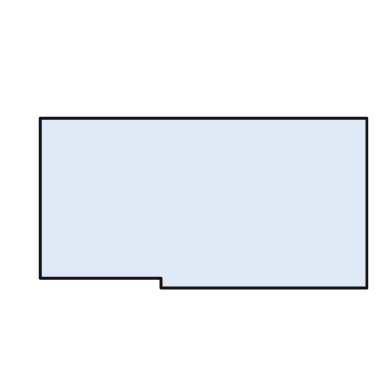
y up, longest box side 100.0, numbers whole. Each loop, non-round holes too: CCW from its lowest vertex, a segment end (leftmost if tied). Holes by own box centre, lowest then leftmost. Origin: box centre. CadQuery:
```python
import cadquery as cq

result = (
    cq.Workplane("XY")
    .moveTo(-13.0, -26.0)
    .lineTo(50.0, -26.0)
    .lineTo(50.0, 26.0)
    .lineTo(-50.0, 26.0)
    .lineTo(-50.0, -23.0)
    .lineTo(-13.0, -23.0)
    .close()
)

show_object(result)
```